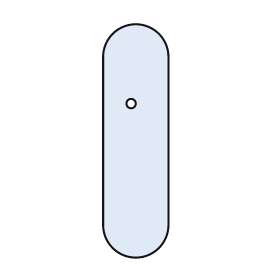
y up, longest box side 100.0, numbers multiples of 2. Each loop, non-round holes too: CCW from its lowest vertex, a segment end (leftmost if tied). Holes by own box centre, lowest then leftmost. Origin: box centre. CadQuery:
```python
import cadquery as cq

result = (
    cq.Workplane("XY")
    .moveTo(-14.0, -36.0)
    .threePointArc((0.0, -50.0), (14.0, -36.0))
    .lineTo(14.0, 36.0)
    .threePointArc((0.0, 50.0), (-14.0, 36.0))
    .close()
    .moveTo(-2.0, 16.0)
    .circle(2.0)
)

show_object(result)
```